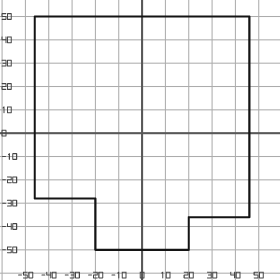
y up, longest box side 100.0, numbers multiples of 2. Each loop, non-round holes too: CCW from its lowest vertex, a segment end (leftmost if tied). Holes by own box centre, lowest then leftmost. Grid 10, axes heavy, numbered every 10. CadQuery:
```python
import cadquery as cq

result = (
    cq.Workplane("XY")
    .moveTo(-20.0, -50.0)
    .lineTo(20.0, -50.0)
    .lineTo(20.0, -36.0)
    .lineTo(46.0, -36.0)
    .lineTo(46.0, 50.0)
    .lineTo(-46.0, 50.0)
    .lineTo(-46.0, -28.0)
    .lineTo(-20.0, -28.0)
    .close()
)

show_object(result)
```